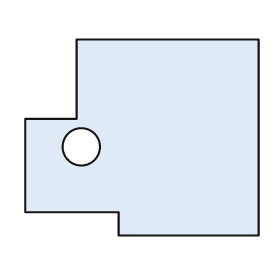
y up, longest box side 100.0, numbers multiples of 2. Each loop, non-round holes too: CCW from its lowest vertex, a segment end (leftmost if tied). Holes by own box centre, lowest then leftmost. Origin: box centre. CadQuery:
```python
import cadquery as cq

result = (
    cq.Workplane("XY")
    .moveTo(-10.0, -42.0)
    .lineTo(50.0, -42.0)
    .lineTo(50.0, 42.0)
    .lineTo(-28.0, 42.0)
    .lineTo(-28.0, 8.0)
    .lineTo(-50.0, 8.0)
    .lineTo(-50.0, -32.0)
    .lineTo(-10.0, -32.0)
    .close()
    .moveTo(-26.0, -4.0)
    .circle(8.0)
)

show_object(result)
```